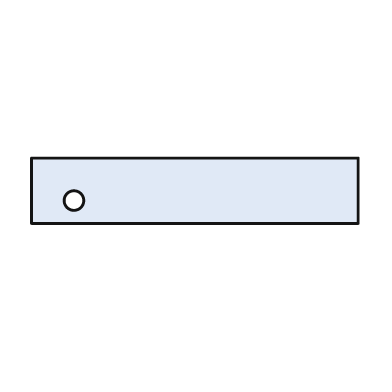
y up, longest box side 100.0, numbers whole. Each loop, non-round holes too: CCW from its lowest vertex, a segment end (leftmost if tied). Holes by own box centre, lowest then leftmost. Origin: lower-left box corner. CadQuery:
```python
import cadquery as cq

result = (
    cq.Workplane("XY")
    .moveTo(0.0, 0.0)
    .lineTo(100.0, 0.0)
    .lineTo(100.0, 20.0)
    .lineTo(0.0, 20.0)
    .close()
    .moveTo(13.0, 7.0)
    .circle(3.0)
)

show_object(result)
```